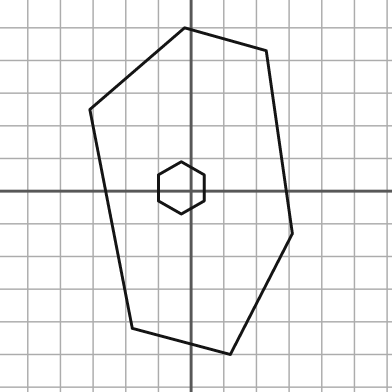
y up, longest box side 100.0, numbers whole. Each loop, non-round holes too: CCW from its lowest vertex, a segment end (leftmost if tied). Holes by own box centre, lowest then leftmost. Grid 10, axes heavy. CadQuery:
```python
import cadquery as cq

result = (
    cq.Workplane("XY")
    .moveTo(12.0, -50.0)
    .lineTo(31.0, -13.0)
    .lineTo(23.0, 43.0)
    .lineTo(-2.0, 50.0)
    .lineTo(-31.0, 25.0)
    .lineTo(-18.0, -42.0)
    .close()
    .moveTo(-3.0, -7.0)
    .lineTo(4.0, -3.0)
    .lineTo(4.0, 5.0)
    .lineTo(-3.0, 9.0)
    .lineTo(-10.0, 5.0)
    .lineTo(-10.0, -3.0)
    .close()
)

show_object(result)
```